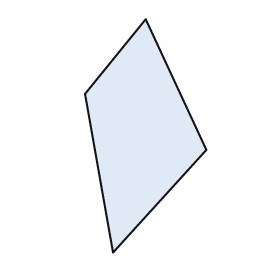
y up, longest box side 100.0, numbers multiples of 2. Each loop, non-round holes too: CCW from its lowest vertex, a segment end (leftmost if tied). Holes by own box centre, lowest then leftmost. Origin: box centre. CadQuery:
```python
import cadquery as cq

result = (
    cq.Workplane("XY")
    .moveTo(-14.0, -50.0)
    .lineTo(26.0, -6.0)
    .lineTo(0.0, 50.0)
    .lineTo(-26.0, 18.0)
    .close()
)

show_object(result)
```